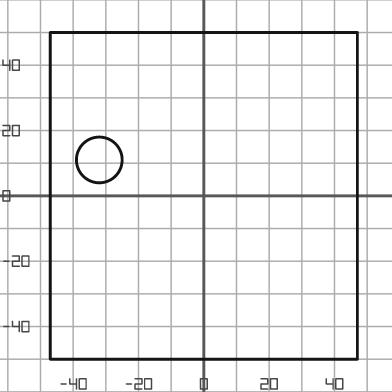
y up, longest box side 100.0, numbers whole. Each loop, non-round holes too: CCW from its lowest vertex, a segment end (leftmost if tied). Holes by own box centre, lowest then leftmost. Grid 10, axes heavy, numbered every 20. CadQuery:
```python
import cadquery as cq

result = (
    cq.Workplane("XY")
    .moveTo(-47.0, -50.0)
    .lineTo(47.0, -50.0)
    .lineTo(47.0, 50.0)
    .lineTo(-47.0, 50.0)
    .close()
    .moveTo(-32.0, 11.0)
    .circle(7.0)
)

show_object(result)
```